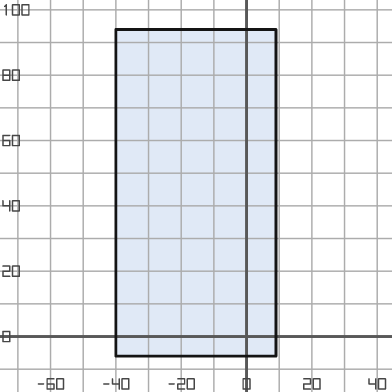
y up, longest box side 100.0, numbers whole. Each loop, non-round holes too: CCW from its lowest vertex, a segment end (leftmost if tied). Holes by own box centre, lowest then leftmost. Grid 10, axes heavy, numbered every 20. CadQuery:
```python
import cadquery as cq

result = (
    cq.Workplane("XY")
    .moveTo(-40.0, -6.0)
    .lineTo(9.0, -6.0)
    .lineTo(9.0, 94.0)
    .lineTo(-40.0, 94.0)
    .close()
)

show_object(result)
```